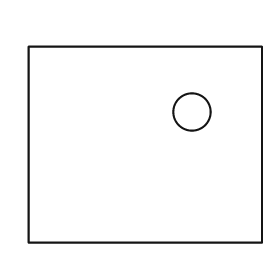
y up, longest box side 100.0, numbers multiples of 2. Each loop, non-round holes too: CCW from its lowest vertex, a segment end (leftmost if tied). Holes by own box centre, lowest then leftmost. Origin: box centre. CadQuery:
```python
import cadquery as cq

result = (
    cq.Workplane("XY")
    .moveTo(-50.0, -42.0)
    .lineTo(50.0, -42.0)
    .lineTo(50.0, 42.0)
    .lineTo(-50.0, 42.0)
    .close()
    .moveTo(20.0, 14.0)
    .circle(8.0)
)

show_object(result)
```